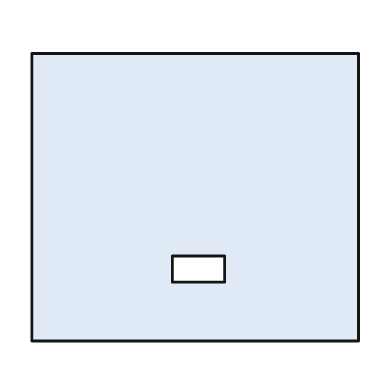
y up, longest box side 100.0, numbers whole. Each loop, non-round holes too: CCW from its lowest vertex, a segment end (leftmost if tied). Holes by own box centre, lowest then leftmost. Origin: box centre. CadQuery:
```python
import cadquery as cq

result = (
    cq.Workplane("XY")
    .moveTo(-50.0, -44.0)
    .lineTo(50.0, -44.0)
    .lineTo(50.0, 44.0)
    .lineTo(-50.0, 44.0)
    .close()
    .moveTo(-7.0, -26.0)
    .lineTo(9.0, -26.0)
    .lineTo(9.0, -18.0)
    .lineTo(-7.0, -18.0)
    .close()
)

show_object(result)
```